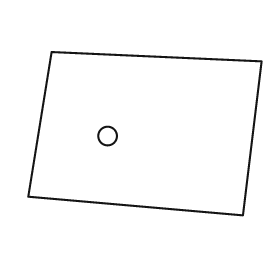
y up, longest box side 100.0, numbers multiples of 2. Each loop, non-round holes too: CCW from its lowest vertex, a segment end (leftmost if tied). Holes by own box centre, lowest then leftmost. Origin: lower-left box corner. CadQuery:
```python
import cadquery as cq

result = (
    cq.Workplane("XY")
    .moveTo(92.0, 0.0)
    .lineTo(100.0, 66.0)
    .lineTo(10.0, 70.0)
    .lineTo(0.0, 8.0)
    .close()
    .moveTo(34.0, 34.0)
    .circle(4.0)
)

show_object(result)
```